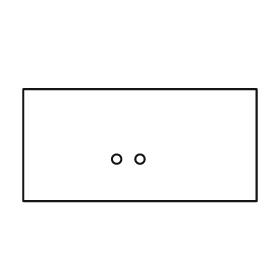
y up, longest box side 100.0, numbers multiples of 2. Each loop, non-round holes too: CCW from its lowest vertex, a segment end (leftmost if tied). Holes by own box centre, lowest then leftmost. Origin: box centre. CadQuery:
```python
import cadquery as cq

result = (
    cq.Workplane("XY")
    .moveTo(-50.0, -24.0)
    .lineTo(50.0, -24.0)
    .lineTo(50.0, 24.0)
    .lineTo(-50.0, 24.0)
    .close()
    .moveTo(-10.0, -6.0)
    .circle(2.0)
    .moveTo(0.0, -6.0)
    .circle(2.0)
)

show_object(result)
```